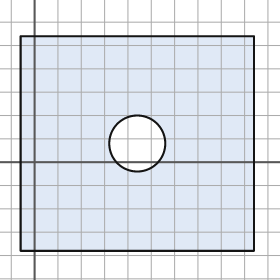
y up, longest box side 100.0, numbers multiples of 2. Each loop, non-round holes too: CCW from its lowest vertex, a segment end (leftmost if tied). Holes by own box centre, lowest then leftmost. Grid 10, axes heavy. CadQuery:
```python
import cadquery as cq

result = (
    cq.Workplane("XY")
    .moveTo(-6.0, -38.0)
    .lineTo(94.0, -38.0)
    .lineTo(94.0, 54.0)
    .lineTo(-6.0, 54.0)
    .close()
    .moveTo(44.0, 8.0)
    .circle(12.0)
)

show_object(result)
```